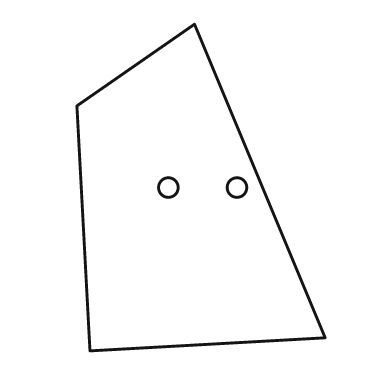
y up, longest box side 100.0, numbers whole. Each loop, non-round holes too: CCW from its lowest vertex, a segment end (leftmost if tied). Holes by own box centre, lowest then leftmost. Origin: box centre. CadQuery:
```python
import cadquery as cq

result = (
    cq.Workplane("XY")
    .moveTo(-34.0, -50.0)
    .lineTo(38.0, -46.0)
    .lineTo(-2.0, 50.0)
    .lineTo(-38.0, 25.0)
    .close()
    .moveTo(-10.0, 0.0)
    .circle(3.0)
    .moveTo(11.0, 0.0)
    .circle(3.0)
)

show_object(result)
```